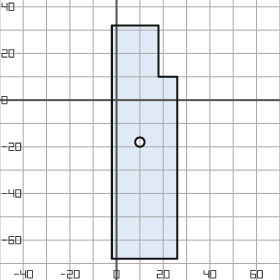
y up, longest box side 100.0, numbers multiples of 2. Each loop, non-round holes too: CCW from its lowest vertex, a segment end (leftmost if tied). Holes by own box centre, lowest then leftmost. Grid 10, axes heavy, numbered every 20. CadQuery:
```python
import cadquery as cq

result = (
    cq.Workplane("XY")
    .moveTo(-2.0, -68.0)
    .lineTo(26.0, -68.0)
    .lineTo(26.0, 10.0)
    .lineTo(18.0, 10.0)
    .lineTo(18.0, 32.0)
    .lineTo(-2.0, 32.0)
    .close()
    .moveTo(10.0, -18.0)
    .circle(2.0)
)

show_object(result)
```